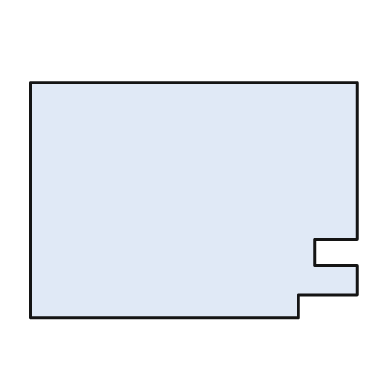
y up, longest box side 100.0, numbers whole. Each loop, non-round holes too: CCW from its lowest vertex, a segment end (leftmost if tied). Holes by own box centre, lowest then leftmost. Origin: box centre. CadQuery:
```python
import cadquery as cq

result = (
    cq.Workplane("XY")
    .moveTo(-50.0, -36.0)
    .lineTo(32.0, -36.0)
    .lineTo(32.0, -29.0)
    .lineTo(50.0, -29.0)
    .lineTo(50.0, -20.0)
    .lineTo(37.0, -20.0)
    .lineTo(37.0, -12.0)
    .lineTo(50.0, -12.0)
    .lineTo(50.0, 36.0)
    .lineTo(-50.0, 36.0)
    .close()
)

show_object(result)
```